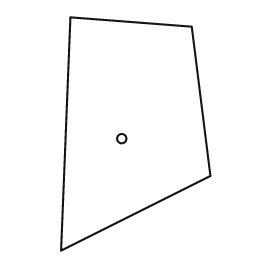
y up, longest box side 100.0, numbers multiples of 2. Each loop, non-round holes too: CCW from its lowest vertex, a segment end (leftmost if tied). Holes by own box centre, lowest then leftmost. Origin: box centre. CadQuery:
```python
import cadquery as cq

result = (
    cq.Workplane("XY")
    .moveTo(-32.0, -50.0)
    .lineTo(32.0, -18.0)
    .lineTo(24.0, 46.0)
    .lineTo(-28.0, 50.0)
    .close()
    .moveTo(-6.0, -2.0)
    .circle(2.0)
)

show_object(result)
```